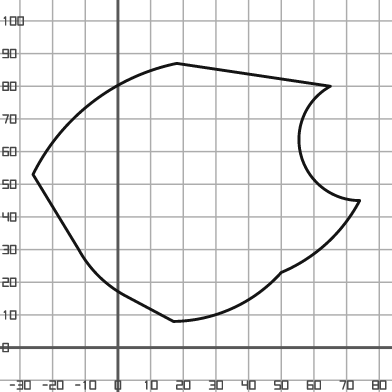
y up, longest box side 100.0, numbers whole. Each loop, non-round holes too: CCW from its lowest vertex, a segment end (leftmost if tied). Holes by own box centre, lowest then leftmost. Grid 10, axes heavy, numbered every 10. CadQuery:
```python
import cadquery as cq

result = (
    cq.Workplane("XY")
    .moveTo(17.0, 8.0)
    .threePointArc((35.0, 12.0), (50.0, 23.0))
    .threePointArc((64.0, 32.0), (74.0, 45.0))
    .threePointArc((56.0, 59.0), (65.0, 80.0))
    .lineTo(18.0, 87.0)
    .threePointArc((-8.0, 75.0), (-26.0, 53.0))
    .lineTo(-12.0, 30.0)
    .threePointArc((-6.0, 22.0), (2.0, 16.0))
    .close()
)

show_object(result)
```